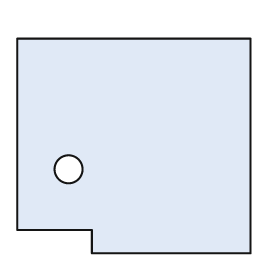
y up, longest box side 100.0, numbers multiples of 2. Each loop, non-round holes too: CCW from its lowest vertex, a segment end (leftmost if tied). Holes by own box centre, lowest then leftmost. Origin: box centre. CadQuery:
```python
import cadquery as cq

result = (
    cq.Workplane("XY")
    .moveTo(-18.0, -46.0)
    .lineTo(50.0, -46.0)
    .lineTo(50.0, 46.0)
    .lineTo(-50.0, 46.0)
    .lineTo(-50.0, -36.0)
    .lineTo(-18.0, -36.0)
    .close()
    .moveTo(-28.0, -10.0)
    .circle(6.0)
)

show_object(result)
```